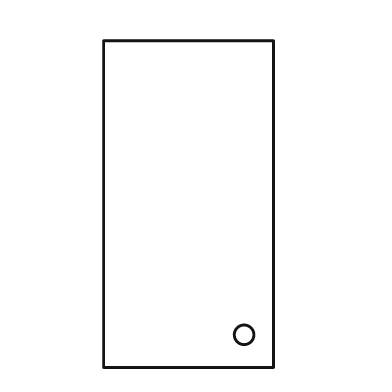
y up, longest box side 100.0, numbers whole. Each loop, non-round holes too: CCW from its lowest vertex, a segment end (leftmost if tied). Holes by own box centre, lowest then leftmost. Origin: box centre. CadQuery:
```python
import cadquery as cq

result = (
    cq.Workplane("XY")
    .moveTo(-26.0, -50.0)
    .lineTo(26.0, -50.0)
    .lineTo(26.0, 50.0)
    .lineTo(-26.0, 50.0)
    .close()
    .moveTo(17.0, -40.0)
    .circle(3.0)
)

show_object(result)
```